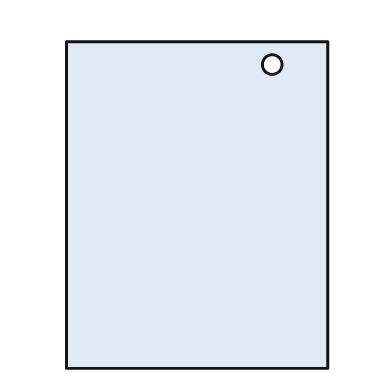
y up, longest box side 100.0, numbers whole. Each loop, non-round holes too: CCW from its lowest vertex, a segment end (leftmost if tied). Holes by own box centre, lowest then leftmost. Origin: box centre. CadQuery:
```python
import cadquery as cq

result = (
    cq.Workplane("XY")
    .moveTo(-40.0, -50.0)
    .lineTo(40.0, -50.0)
    .lineTo(40.0, 50.0)
    .lineTo(-40.0, 50.0)
    .close()
    .moveTo(23.0, 43.0)
    .circle(3.0)
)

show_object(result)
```